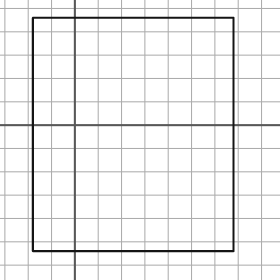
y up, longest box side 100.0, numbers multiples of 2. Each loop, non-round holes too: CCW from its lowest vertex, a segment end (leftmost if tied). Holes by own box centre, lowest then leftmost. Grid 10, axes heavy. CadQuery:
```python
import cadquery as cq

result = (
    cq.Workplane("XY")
    .moveTo(-18.0, -54.0)
    .lineTo(68.0, -54.0)
    .lineTo(68.0, 46.0)
    .lineTo(-18.0, 46.0)
    .close()
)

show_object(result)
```